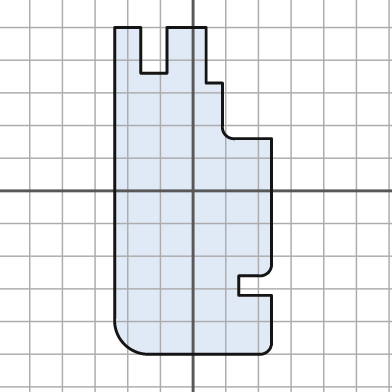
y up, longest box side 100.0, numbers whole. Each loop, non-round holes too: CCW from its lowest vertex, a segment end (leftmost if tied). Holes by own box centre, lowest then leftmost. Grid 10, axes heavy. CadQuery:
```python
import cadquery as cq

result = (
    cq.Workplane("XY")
    .moveTo(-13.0, -50.0)
    .lineTo(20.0, -50.0)
    .threePointArc((23.0, -49.0), (24.0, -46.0))
    .lineTo(24.0, -32.0)
    .lineTo(14.0, -32.0)
    .lineTo(14.0, -26.0)
    .lineTo(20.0, -26.0)
    .threePointArc((23.0, -25.0), (24.0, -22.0))
    .lineTo(24.0, 16.0)
    .lineTo(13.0, 16.0)
    .threePointArc((10.0, 17.0), (9.0, 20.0))
    .lineTo(9.0, 33.0)
    .lineTo(4.0, 33.0)
    .lineTo(4.0, 50.0)
    .lineTo(-8.0, 50.0)
    .lineTo(-8.0, 36.0)
    .lineTo(-16.0, 36.0)
    .lineTo(-16.0, 50.0)
    .lineTo(-24.0, 50.0)
    .lineTo(-24.0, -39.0)
    .threePointArc((-21.0, -47.0), (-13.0, -50.0))
    .close()
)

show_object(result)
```